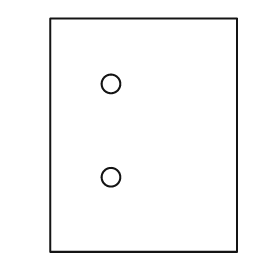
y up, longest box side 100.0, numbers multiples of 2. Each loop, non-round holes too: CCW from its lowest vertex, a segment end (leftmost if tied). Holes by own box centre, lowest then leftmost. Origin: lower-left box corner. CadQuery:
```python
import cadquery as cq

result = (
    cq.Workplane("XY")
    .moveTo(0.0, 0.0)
    .lineTo(80.0, 0.0)
    .lineTo(80.0, 100.0)
    .lineTo(0.0, 100.0)
    .close()
    .moveTo(26.0, 32.0)
    .circle(4.0)
    .moveTo(26.0, 72.0)
    .circle(4.0)
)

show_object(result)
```